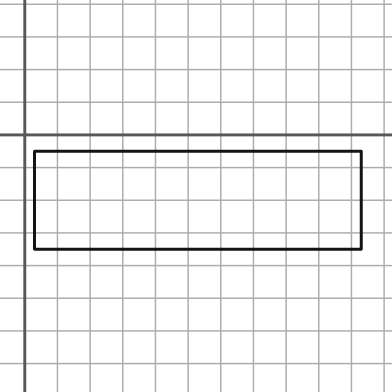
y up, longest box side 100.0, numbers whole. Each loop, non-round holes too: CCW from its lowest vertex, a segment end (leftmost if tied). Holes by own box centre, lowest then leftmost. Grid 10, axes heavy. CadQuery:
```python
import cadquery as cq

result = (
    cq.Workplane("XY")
    .moveTo(3.0, -35.0)
    .lineTo(103.0, -35.0)
    .lineTo(103.0, -5.0)
    .lineTo(3.0, -5.0)
    .close()
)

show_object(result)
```